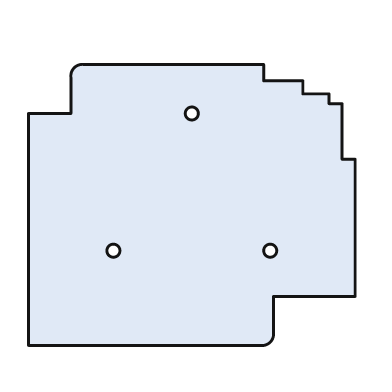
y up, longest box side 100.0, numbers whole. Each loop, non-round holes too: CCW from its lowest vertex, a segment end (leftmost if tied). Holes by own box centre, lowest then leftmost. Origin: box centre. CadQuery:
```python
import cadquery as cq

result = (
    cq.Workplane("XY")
    .moveTo(-50.0, -43.0)
    .lineTo(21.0, -43.0)
    .threePointArc((24.0, -42.0), (25.0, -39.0))
    .lineTo(25.0, -28.0)
    .lineTo(50.0, -28.0)
    .lineTo(50.0, 14.0)
    .lineTo(46.0, 14.0)
    .lineTo(46.0, 31.0)
    .lineTo(42.0, 31.0)
    .lineTo(42.0, 34.0)
    .lineTo(34.0, 34.0)
    .lineTo(34.0, 38.0)
    .lineTo(22.0, 38.0)
    .lineTo(22.0, 43.0)
    .lineTo(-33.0, 43.0)
    .threePointArc((-36.0, 42.0), (-37.0, 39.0))
    .lineTo(-37.0, 28.0)
    .lineTo(-50.0, 28.0)
    .close()
    .moveTo(-24.0, -14.0)
    .circle(2.0)
    .moveTo(24.0, -14.0)
    .circle(2.0)
    .moveTo(0.0, 28.0)
    .circle(2.0)
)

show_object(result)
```